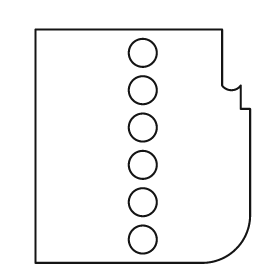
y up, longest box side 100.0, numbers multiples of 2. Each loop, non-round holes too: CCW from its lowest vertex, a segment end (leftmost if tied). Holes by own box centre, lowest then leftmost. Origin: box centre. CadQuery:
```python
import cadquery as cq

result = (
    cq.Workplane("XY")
    .moveTo(-46.0, -50.0)
    .lineTo(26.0, -50.0)
    .threePointArc((40.0, -44.0), (46.0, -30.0))
    .lineTo(46.0, 16.0)
    .lineTo(42.0, 16.0)
    .lineTo(42.0, 26.0)
    .threePointArc((38.0, 24.0), (34.0, 26.0))
    .lineTo(34.0, 50.0)
    .lineTo(-46.0, 50.0)
    .close()
    .moveTo(0.0, -40.0)
    .circle(6.0)
    .moveTo(0.0, -24.0)
    .circle(6.0)
    .moveTo(0.0, -8.0)
    .circle(6.0)
    .moveTo(0.0, 8.0)
    .circle(6.0)
    .moveTo(0.0, 24.0)
    .circle(6.0)
    .moveTo(0.0, 40.0)
    .circle(6.0)
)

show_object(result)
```